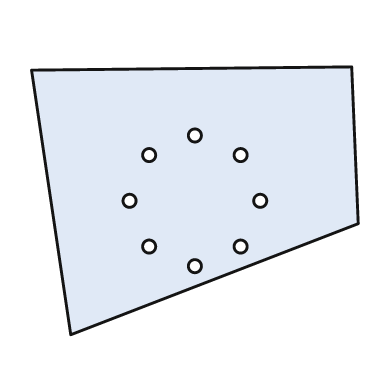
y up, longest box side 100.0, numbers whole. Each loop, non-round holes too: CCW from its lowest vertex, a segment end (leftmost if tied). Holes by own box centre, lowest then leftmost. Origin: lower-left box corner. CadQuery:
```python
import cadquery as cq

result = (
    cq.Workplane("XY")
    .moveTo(12.0, 0.0)
    .lineTo(100.0, 34.0)
    .lineTo(98.0, 82.0)
    .lineTo(0.0, 81.0)
    .close()
    .moveTo(50.0, 21.0)
    .circle(2.0)
    .moveTo(36.0, 27.0)
    .circle(2.0)
    .moveTo(64.0, 27.0)
    .circle(2.0)
    .moveTo(30.0, 41.0)
    .circle(2.0)
    .moveTo(70.0, 41.0)
    .circle(2.0)
    .moveTo(36.0, 55.0)
    .circle(2.0)
    .moveTo(64.0, 55.0)
    .circle(2.0)
    .moveTo(50.0, 61.0)
    .circle(2.0)
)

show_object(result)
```